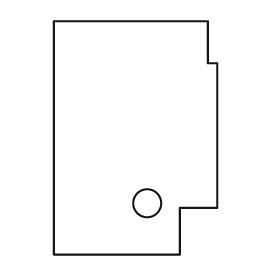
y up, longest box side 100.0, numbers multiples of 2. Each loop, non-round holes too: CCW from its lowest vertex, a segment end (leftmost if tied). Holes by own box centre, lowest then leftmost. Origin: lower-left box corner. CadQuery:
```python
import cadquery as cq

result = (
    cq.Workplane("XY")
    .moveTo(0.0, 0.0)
    .lineTo(54.0, 0.0)
    .lineTo(54.0, 20.0)
    .lineTo(70.0, 20.0)
    .lineTo(70.0, 82.0)
    .lineTo(66.0, 82.0)
    .lineTo(66.0, 100.0)
    .lineTo(0.0, 100.0)
    .close()
    .moveTo(40.0, 22.0)
    .circle(6.0)
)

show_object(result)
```